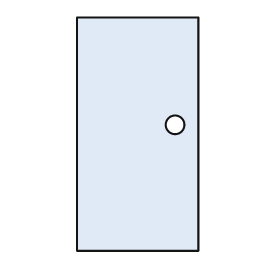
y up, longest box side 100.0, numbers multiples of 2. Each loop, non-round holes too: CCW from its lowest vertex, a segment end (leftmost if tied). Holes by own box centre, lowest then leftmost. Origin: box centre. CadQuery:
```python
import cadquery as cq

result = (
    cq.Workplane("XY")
    .moveTo(-26.0, -50.0)
    .lineTo(26.0, -50.0)
    .lineTo(26.0, 50.0)
    .lineTo(-26.0, 50.0)
    .close()
    .moveTo(16.0, 4.0)
    .circle(4.0)
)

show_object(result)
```